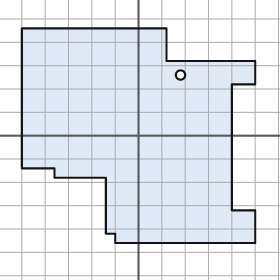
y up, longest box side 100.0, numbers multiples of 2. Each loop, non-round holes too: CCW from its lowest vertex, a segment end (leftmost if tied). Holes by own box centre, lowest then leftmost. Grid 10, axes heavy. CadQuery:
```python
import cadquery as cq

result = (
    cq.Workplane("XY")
    .moveTo(-10.0, -46.0)
    .lineTo(50.0, -46.0)
    .lineTo(50.0, -32.0)
    .lineTo(40.0, -32.0)
    .lineTo(40.0, 22.0)
    .lineTo(50.0, 22.0)
    .lineTo(50.0, 32.0)
    .lineTo(12.0, 32.0)
    .lineTo(12.0, 46.0)
    .lineTo(-50.0, 46.0)
    .lineTo(-50.0, -14.0)
    .lineTo(-36.0, -14.0)
    .lineTo(-36.0, -18.0)
    .lineTo(-14.0, -18.0)
    .lineTo(-14.0, -42.0)
    .lineTo(-10.0, -42.0)
    .close()
    .moveTo(18.0, 26.0)
    .circle(2.0)
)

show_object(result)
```